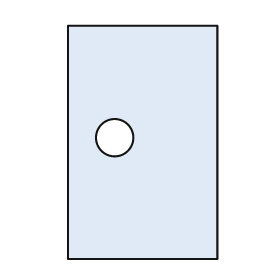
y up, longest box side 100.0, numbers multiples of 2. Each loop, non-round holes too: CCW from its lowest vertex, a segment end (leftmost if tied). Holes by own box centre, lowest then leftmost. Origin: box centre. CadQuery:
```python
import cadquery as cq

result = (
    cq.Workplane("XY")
    .moveTo(-32.0, -50.0)
    .lineTo(32.0, -50.0)
    .lineTo(32.0, 50.0)
    .lineTo(-32.0, 50.0)
    .close()
    .moveTo(-12.0, 2.0)
    .circle(8.0)
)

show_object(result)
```